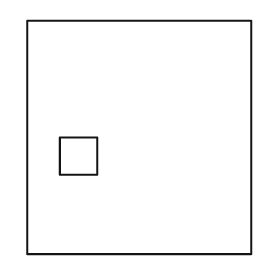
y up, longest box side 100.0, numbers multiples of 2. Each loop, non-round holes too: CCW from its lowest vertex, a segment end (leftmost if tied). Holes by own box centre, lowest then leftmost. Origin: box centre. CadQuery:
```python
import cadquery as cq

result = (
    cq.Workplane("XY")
    .moveTo(-48.0, -50.0)
    .lineTo(48.0, -50.0)
    .lineTo(48.0, 50.0)
    .lineTo(-48.0, 50.0)
    .close()
    .moveTo(-34.0, -16.0)
    .lineTo(-18.0, -16.0)
    .lineTo(-18.0, 0.0)
    .lineTo(-34.0, 0.0)
    .close()
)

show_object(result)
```